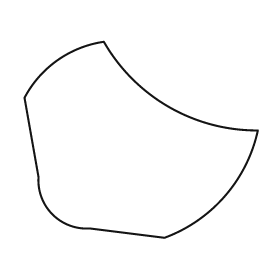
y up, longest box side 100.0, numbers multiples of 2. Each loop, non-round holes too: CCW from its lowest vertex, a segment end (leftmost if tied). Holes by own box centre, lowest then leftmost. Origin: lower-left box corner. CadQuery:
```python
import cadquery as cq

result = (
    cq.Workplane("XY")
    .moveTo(60.0, 0.0)
    .threePointArc((86.0, 18.0), (100.0, 46.0))
    .threePointArc((62.0, 56.0), (34.0, 84.0))
    .threePointArc((14.0, 76.0), (0.0, 60.0))
    .lineTo(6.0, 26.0)
    .threePointArc((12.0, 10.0), (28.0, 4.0))
    .close()
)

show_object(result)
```